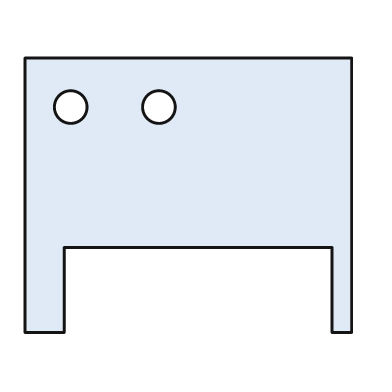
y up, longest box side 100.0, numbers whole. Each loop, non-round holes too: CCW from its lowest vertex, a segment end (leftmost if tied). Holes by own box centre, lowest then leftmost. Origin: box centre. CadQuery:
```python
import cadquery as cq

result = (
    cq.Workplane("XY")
    .moveTo(-50.0, -42.0)
    .lineTo(-38.0, -42.0)
    .lineTo(-38.0, -16.0)
    .lineTo(44.0, -16.0)
    .lineTo(44.0, -42.0)
    .lineTo(50.0, -42.0)
    .lineTo(50.0, 42.0)
    .lineTo(-50.0, 42.0)
    .close()
    .moveTo(-36.0, 27.0)
    .circle(5.0)
    .moveTo(-9.0, 27.0)
    .circle(5.0)
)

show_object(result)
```